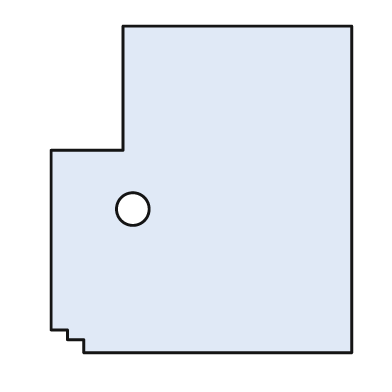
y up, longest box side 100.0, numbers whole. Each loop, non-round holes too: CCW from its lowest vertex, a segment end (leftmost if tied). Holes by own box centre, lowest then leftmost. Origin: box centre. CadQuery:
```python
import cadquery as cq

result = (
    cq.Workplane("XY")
    .moveTo(-36.0, -50.0)
    .lineTo(46.0, -50.0)
    .lineTo(46.0, 50.0)
    .lineTo(-24.0, 50.0)
    .lineTo(-24.0, 12.0)
    .lineTo(-46.0, 12.0)
    .lineTo(-46.0, -43.0)
    .lineTo(-41.0, -43.0)
    .lineTo(-41.0, -46.0)
    .lineTo(-36.0, -46.0)
    .close()
    .moveTo(-21.0, -6.0)
    .circle(5.0)
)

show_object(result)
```